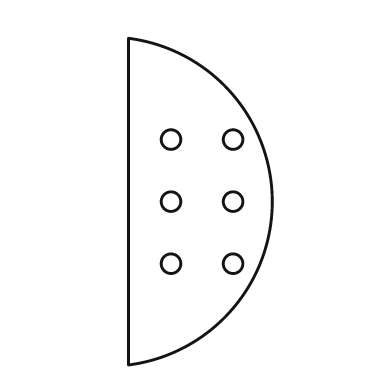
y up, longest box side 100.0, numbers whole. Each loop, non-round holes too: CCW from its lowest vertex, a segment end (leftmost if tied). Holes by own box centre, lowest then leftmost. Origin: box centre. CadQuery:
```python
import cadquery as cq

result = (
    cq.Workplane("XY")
    .moveTo(-22.0, -50.0)
    .threePointArc((22.0, 0.0), (-22.0, 50.0))
    .close()
    .moveTo(-9.0, -19.0)
    .circle(3.0)
    .moveTo(10.0, -19.0)
    .circle(3.0)
    .moveTo(-9.0, 0.0)
    .circle(3.0)
    .moveTo(10.0, 0.0)
    .circle(3.0)
    .moveTo(-9.0, 19.0)
    .circle(3.0)
    .moveTo(10.0, 19.0)
    .circle(3.0)
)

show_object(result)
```